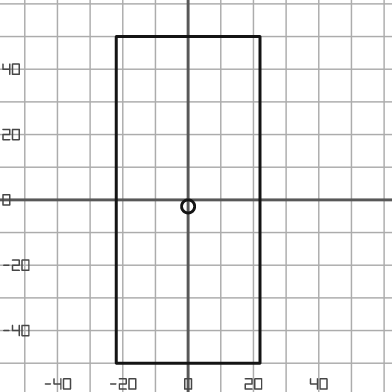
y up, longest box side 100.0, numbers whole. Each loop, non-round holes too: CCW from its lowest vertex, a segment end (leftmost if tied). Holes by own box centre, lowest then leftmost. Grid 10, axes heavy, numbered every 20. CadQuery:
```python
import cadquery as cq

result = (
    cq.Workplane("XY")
    .moveTo(-22.0, -50.0)
    .lineTo(22.0, -50.0)
    .lineTo(22.0, 50.0)
    .lineTo(-22.0, 50.0)
    .close()
    .moveTo(0.0, -2.0)
    .circle(2.0)
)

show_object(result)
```